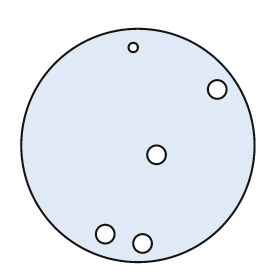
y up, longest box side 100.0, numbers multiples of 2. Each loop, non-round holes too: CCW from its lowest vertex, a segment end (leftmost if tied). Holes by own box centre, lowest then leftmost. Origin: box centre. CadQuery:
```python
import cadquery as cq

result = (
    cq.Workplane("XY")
    .moveTo(0.0, 0.0)
    .circle(50.0)
    .moveTo(2.0, -42.0)
    .circle(4.0)
    .moveTo(-14.0, -38.0)
    .circle(4.0)
    .moveTo(8.0, -4.0)
    .circle(4.0)
    .moveTo(34.0, 24.0)
    .circle(4.0)
    .moveTo(-2.0, 42.0)
    .circle(2.0)
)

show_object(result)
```